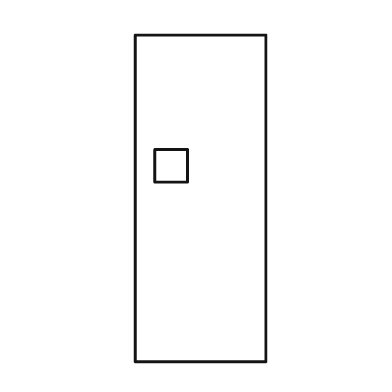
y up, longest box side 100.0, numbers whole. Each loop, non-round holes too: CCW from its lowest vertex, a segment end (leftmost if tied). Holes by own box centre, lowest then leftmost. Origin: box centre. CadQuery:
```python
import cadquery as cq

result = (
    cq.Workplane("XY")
    .moveTo(-20.0, -50.0)
    .lineTo(20.0, -50.0)
    .lineTo(20.0, 50.0)
    .lineTo(-20.0, 50.0)
    .close()
    .moveTo(-14.0, 5.0)
    .lineTo(-4.0, 5.0)
    .lineTo(-4.0, 15.0)
    .lineTo(-14.0, 15.0)
    .close()
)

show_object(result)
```